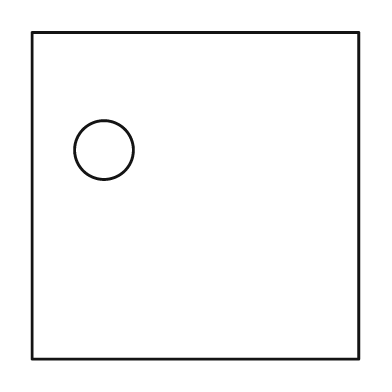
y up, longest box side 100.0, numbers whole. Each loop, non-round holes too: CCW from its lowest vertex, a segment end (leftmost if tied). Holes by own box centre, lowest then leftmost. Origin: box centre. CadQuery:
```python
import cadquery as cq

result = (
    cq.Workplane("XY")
    .moveTo(-50.0, -50.0)
    .lineTo(50.0, -50.0)
    .lineTo(50.0, 50.0)
    .lineTo(-50.0, 50.0)
    .close()
    .moveTo(-28.0, 14.0)
    .circle(9.0)
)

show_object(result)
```